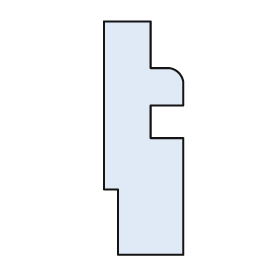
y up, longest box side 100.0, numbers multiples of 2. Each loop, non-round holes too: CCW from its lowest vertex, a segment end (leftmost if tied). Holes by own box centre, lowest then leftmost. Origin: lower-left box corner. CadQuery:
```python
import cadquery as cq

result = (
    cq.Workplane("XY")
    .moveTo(6.0, 0.0)
    .lineTo(34.0, 0.0)
    .lineTo(34.0, 50.0)
    .lineTo(20.0, 50.0)
    .lineTo(20.0, 64.0)
    .lineTo(34.0, 64.0)
    .lineTo(34.0, 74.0)
    .threePointArc((32.0, 78.0), (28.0, 80.0))
    .lineTo(20.0, 80.0)
    .lineTo(20.0, 100.0)
    .lineTo(0.0, 100.0)
    .lineTo(0.0, 28.0)
    .lineTo(6.0, 28.0)
    .close()
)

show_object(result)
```